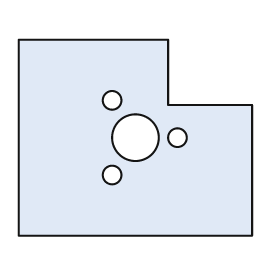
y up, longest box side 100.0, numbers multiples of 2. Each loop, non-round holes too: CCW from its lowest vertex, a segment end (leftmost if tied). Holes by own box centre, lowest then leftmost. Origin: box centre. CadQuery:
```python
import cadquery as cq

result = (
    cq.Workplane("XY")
    .moveTo(-50.0, -42.0)
    .lineTo(50.0, -42.0)
    .lineTo(50.0, 14.0)
    .lineTo(14.0, 14.0)
    .lineTo(14.0, 42.0)
    .lineTo(-50.0, 42.0)
    .close()
    .moveTo(-10.0, -16.0)
    .circle(4.0)
    .moveTo(0.0, 0.0)
    .circle(10.0)
    .moveTo(18.0, 0.0)
    .circle(4.0)
    .moveTo(-10.0, 16.0)
    .circle(4.0)
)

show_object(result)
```